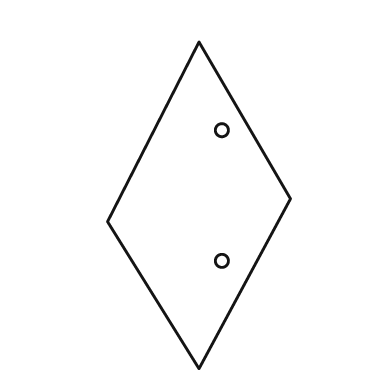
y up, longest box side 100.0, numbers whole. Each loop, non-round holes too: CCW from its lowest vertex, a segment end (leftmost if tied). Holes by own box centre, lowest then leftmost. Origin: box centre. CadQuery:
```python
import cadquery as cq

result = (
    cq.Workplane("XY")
    .moveTo(0.0, -50.0)
    .lineTo(28.0, 2.0)
    .lineTo(0.0, 50.0)
    .lineTo(-28.0, -5.0)
    .close()
    .moveTo(7.0, -17.0)
    .circle(2.0)
    .moveTo(7.0, 23.0)
    .circle(2.0)
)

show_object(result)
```